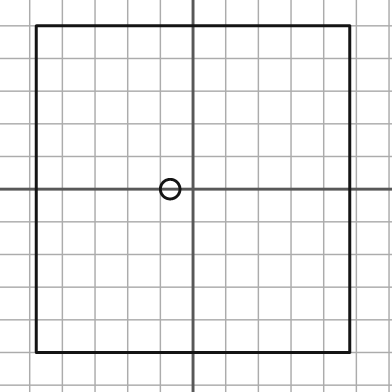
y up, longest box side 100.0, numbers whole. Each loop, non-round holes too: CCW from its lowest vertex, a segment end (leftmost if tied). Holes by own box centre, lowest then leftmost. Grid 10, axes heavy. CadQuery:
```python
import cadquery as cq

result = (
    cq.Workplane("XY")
    .moveTo(-48.0, -50.0)
    .lineTo(48.0, -50.0)
    .lineTo(48.0, 50.0)
    .lineTo(-48.0, 50.0)
    .close()
    .moveTo(-7.0, 0.0)
    .circle(3.0)
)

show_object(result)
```